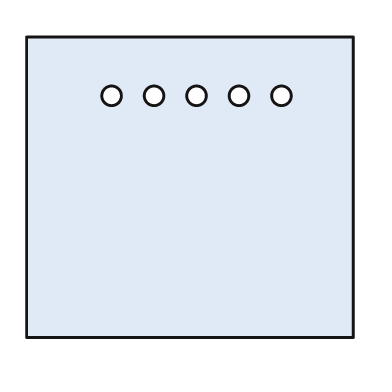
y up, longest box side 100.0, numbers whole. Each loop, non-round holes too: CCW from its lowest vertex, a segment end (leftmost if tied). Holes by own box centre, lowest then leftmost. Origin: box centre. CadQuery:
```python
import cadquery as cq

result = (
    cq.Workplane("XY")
    .moveTo(-50.0, -46.0)
    .lineTo(50.0, -46.0)
    .lineTo(50.0, 46.0)
    .lineTo(-50.0, 46.0)
    .close()
    .moveTo(-24.0, 28.0)
    .circle(3.0)
    .moveTo(-11.0, 28.0)
    .circle(3.0)
    .moveTo(2.0, 28.0)
    .circle(3.0)
    .moveTo(15.0, 28.0)
    .circle(3.0)
    .moveTo(28.0, 28.0)
    .circle(3.0)
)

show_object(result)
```